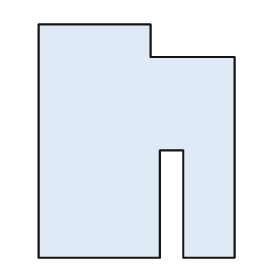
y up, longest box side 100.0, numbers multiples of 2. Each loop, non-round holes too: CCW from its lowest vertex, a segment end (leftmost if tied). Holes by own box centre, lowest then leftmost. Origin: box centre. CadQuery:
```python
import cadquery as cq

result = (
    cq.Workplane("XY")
    .moveTo(-42.0, -50.0)
    .lineTo(10.0, -50.0)
    .lineTo(10.0, -4.0)
    .lineTo(20.0, -4.0)
    .lineTo(20.0, -50.0)
    .lineTo(42.0, -50.0)
    .lineTo(42.0, 36.0)
    .lineTo(6.0, 36.0)
    .lineTo(6.0, 50.0)
    .lineTo(-42.0, 50.0)
    .close()
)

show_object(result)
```